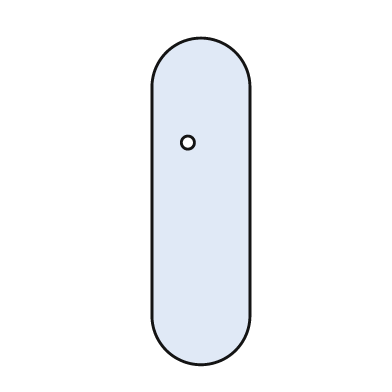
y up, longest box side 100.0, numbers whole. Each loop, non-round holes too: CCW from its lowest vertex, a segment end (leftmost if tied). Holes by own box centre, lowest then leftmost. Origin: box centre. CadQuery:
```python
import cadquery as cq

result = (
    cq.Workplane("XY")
    .moveTo(-15.0, -35.0)
    .threePointArc((0.0, -50.0), (15.0, -35.0))
    .lineTo(15.0, 35.0)
    .threePointArc((0.0, 50.0), (-15.0, 35.0))
    .close()
    .moveTo(-4.0, 18.0)
    .circle(2.0)
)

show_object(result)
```